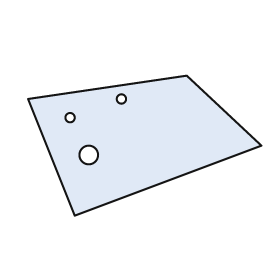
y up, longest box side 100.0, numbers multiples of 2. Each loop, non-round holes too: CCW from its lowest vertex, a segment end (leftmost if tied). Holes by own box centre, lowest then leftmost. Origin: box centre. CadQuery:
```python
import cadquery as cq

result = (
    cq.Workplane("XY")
    .moveTo(-30.0, -30.0)
    .lineTo(50.0, 0.0)
    .lineTo(18.0, 30.0)
    .lineTo(-50.0, 20.0)
    .close()
    .moveTo(-24.0, -4.0)
    .circle(4.0)
    .moveTo(-32.0, 12.0)
    .circle(2.0)
    .moveTo(-10.0, 20.0)
    .circle(2.0)
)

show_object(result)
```